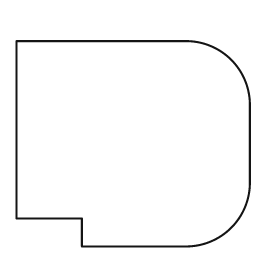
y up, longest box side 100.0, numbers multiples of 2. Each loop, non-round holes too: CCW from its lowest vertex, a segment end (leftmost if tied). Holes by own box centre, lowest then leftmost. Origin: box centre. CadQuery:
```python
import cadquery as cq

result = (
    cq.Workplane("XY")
    .moveTo(-22.0, -44.0)
    .lineTo(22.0, -44.0)
    .threePointArc((42.0, -36.0), (50.0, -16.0))
    .lineTo(50.0, 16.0)
    .threePointArc((42.0, 36.0), (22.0, 44.0))
    .lineTo(-50.0, 44.0)
    .lineTo(-50.0, -32.0)
    .lineTo(-22.0, -32.0)
    .close()
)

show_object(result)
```